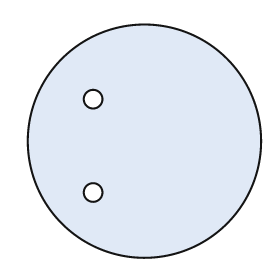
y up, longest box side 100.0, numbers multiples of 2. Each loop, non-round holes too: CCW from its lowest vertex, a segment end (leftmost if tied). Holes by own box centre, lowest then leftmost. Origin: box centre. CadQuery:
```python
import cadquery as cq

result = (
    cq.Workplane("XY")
    .moveTo(0.0, 0.0)
    .circle(50.0)
    .moveTo(-22.0, -22.0)
    .circle(4.0)
    .moveTo(-22.0, 18.0)
    .circle(4.0)
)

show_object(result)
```